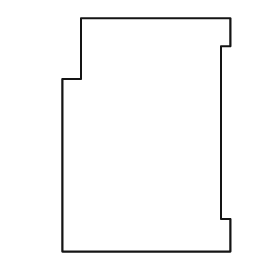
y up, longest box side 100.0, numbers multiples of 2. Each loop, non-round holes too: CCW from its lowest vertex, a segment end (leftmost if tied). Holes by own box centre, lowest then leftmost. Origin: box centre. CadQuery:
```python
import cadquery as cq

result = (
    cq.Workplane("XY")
    .moveTo(-36.0, -50.0)
    .lineTo(36.0, -50.0)
    .lineTo(36.0, -36.0)
    .lineTo(32.0, -36.0)
    .lineTo(32.0, 38.0)
    .lineTo(36.0, 38.0)
    .lineTo(36.0, 50.0)
    .lineTo(-28.0, 50.0)
    .lineTo(-28.0, 24.0)
    .lineTo(-36.0, 24.0)
    .close()
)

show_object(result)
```